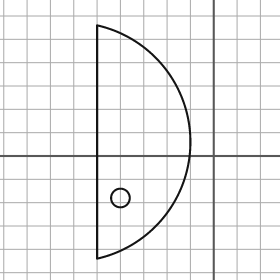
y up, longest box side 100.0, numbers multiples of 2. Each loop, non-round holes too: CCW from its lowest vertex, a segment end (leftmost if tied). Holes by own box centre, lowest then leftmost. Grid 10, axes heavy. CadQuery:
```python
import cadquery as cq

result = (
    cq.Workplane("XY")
    .moveTo(-50.0, -44.0)
    .threePointArc((-10.0, 6.0), (-50.0, 56.0))
    .close()
    .moveTo(-40.0, -18.0)
    .circle(4.0)
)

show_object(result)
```